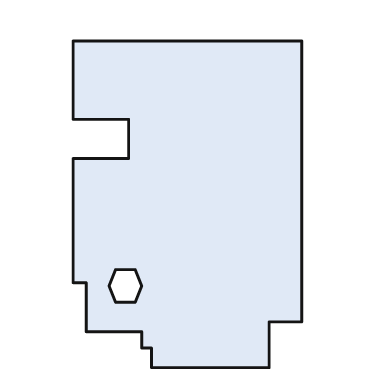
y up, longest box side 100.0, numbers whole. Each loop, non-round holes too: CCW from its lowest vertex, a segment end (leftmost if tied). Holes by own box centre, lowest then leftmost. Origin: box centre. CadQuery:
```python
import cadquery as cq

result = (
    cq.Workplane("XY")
    .moveTo(-11.0, -50.0)
    .lineTo(25.0, -50.0)
    .lineTo(25.0, -36.0)
    .lineTo(35.0, -36.0)
    .lineTo(35.0, 50.0)
    .lineTo(-35.0, 50.0)
    .lineTo(-35.0, 26.0)
    .lineTo(-18.0, 26.0)
    .lineTo(-18.0, 14.0)
    .lineTo(-35.0, 14.0)
    .lineTo(-35.0, -24.0)
    .lineTo(-31.0, -24.0)
    .lineTo(-31.0, -39.0)
    .lineTo(-14.0, -39.0)
    .lineTo(-14.0, -44.0)
    .lineTo(-11.0, -44.0)
    .close()
    .moveTo(-22.0, -30.0)
    .lineTo(-16.0, -30.0)
    .lineTo(-14.0, -25.0)
    .lineTo(-16.0, -20.0)
    .lineTo(-22.0, -20.0)
    .lineTo(-24.0, -25.0)
    .close()
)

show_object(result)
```